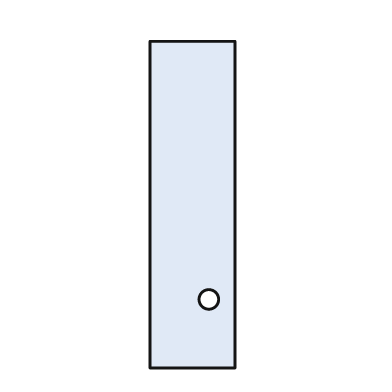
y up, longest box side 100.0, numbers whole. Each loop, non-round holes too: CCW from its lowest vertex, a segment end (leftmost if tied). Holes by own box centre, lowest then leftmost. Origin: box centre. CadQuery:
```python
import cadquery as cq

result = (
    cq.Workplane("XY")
    .moveTo(-13.0, -50.0)
    .lineTo(13.0, -50.0)
    .lineTo(13.0, 50.0)
    .lineTo(-13.0, 50.0)
    .close()
    .moveTo(5.0, -29.0)
    .circle(3.0)
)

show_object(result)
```